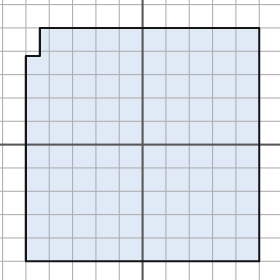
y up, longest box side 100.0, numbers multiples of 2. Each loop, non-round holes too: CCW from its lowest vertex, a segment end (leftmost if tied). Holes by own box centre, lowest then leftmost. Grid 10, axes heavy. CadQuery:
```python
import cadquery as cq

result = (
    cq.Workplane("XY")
    .moveTo(-50.0, -50.0)
    .lineTo(50.0, -50.0)
    .lineTo(50.0, 50.0)
    .lineTo(-44.0, 50.0)
    .lineTo(-44.0, 38.0)
    .lineTo(-50.0, 38.0)
    .close()
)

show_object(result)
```